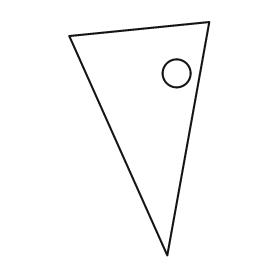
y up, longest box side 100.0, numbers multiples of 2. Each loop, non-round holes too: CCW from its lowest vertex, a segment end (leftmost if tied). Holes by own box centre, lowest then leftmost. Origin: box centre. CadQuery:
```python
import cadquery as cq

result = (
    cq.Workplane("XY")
    .moveTo(12.0, -50.0)
    .lineTo(30.0, 50.0)
    .lineTo(-30.0, 44.0)
    .close()
    .moveTo(16.0, 28.0)
    .circle(6.0)
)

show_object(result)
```